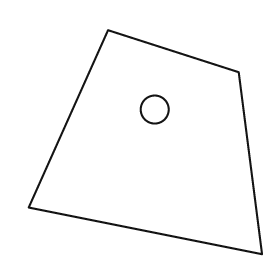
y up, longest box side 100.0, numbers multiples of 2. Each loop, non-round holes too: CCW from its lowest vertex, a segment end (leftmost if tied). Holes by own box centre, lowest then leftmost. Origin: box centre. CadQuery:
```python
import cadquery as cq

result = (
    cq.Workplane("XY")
    .moveTo(50.0, -48.0)
    .lineTo(40.0, 30.0)
    .lineTo(-16.0, 48.0)
    .lineTo(-50.0, -28.0)
    .close()
    .moveTo(4.0, 14.0)
    .circle(6.0)
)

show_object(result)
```